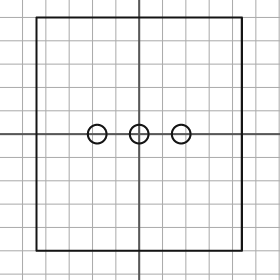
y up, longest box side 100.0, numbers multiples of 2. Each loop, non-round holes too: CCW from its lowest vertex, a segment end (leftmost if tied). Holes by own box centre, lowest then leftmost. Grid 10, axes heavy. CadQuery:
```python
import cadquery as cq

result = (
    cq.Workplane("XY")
    .moveTo(-44.0, -50.0)
    .lineTo(44.0, -50.0)
    .lineTo(44.0, 50.0)
    .lineTo(-44.0, 50.0)
    .close()
    .moveTo(-18.0, 0.0)
    .circle(4.0)
    .moveTo(0.0, 0.0)
    .circle(4.0)
    .moveTo(18.0, 0.0)
    .circle(4.0)
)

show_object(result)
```